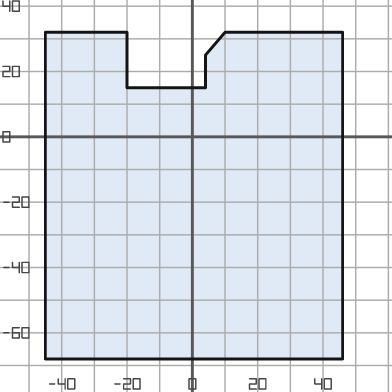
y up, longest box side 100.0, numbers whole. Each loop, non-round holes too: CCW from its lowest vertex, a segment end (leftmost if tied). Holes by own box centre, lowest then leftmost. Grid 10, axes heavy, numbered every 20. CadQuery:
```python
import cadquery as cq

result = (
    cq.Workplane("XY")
    .moveTo(-45.0, -68.0)
    .lineTo(46.0, -68.0)
    .lineTo(46.0, 32.0)
    .lineTo(10.0, 32.0)
    .lineTo(4.0, 25.0)
    .lineTo(4.0, 15.0)
    .lineTo(-20.0, 15.0)
    .lineTo(-20.0, 32.0)
    .lineTo(-45.0, 32.0)
    .close()
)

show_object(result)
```